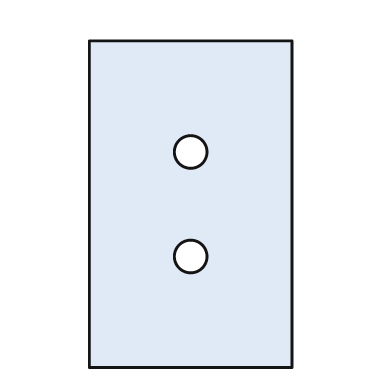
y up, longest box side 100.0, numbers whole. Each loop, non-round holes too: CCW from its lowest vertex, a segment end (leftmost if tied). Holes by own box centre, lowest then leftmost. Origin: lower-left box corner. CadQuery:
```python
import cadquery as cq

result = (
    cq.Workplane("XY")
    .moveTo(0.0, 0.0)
    .lineTo(62.0, 0.0)
    .lineTo(62.0, 100.0)
    .lineTo(0.0, 100.0)
    .close()
    .moveTo(31.0, 34.0)
    .circle(5.0)
    .moveTo(31.0, 66.0)
    .circle(5.0)
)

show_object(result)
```